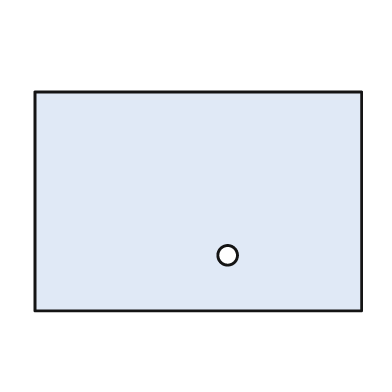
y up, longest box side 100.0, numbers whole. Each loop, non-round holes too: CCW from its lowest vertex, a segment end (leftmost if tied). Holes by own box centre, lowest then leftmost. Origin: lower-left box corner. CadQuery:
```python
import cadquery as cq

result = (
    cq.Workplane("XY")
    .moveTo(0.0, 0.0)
    .lineTo(100.0, 0.0)
    .lineTo(100.0, 67.0)
    .lineTo(0.0, 67.0)
    .close()
    .moveTo(59.0, 17.0)
    .circle(3.0)
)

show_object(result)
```